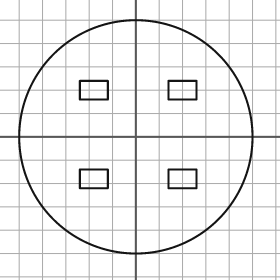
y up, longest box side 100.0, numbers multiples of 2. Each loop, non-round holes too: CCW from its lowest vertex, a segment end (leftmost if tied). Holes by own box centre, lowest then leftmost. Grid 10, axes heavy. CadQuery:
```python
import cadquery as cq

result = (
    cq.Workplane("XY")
    .moveTo(0.0, 0.0)
    .circle(50.0)
    .moveTo(-24.0, -22.0)
    .lineTo(-12.0, -22.0)
    .lineTo(-12.0, -14.0)
    .lineTo(-24.0, -14.0)
    .close()
    .moveTo(14.0, -22.0)
    .lineTo(26.0, -22.0)
    .lineTo(26.0, -14.0)
    .lineTo(14.0, -14.0)
    .close()
    .moveTo(-24.0, 16.0)
    .lineTo(-12.0, 16.0)
    .lineTo(-12.0, 24.0)
    .lineTo(-24.0, 24.0)
    .close()
    .moveTo(14.0, 16.0)
    .lineTo(26.0, 16.0)
    .lineTo(26.0, 24.0)
    .lineTo(14.0, 24.0)
    .close()
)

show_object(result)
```